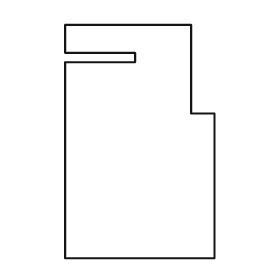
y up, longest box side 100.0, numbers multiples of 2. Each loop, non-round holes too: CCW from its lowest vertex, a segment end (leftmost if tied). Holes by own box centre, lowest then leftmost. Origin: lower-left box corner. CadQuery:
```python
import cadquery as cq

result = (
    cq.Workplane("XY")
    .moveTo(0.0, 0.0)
    .lineTo(64.0, 0.0)
    .lineTo(64.0, 62.0)
    .lineTo(54.0, 62.0)
    .lineTo(54.0, 100.0)
    .lineTo(0.0, 100.0)
    .lineTo(0.0, 88.0)
    .lineTo(30.0, 88.0)
    .lineTo(30.0, 84.0)
    .lineTo(0.0, 84.0)
    .close()
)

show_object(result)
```